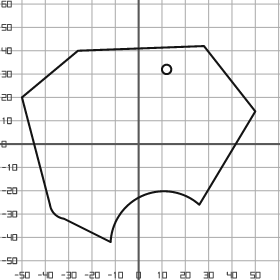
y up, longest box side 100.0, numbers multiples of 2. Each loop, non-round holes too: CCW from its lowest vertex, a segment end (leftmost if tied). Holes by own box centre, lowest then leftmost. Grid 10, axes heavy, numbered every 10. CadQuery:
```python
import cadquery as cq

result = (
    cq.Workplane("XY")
    .moveTo(-12.0, -42.0)
    .threePointArc((2.0, -22.0), (26.0, -26.0))
    .lineTo(50.0, 14.0)
    .lineTo(28.0, 42.0)
    .lineTo(-26.0, 40.0)
    .lineTo(-50.0, 20.0)
    .lineTo(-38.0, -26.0)
    .threePointArc((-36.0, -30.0), (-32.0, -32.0))
    .close()
    .moveTo(12.0, 32.0)
    .circle(2.0)
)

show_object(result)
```